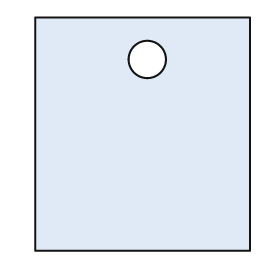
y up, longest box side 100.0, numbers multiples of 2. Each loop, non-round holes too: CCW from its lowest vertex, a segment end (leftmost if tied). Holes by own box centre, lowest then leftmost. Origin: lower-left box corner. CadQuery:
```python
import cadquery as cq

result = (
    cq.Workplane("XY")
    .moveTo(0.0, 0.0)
    .lineTo(92.0, 0.0)
    .lineTo(92.0, 100.0)
    .lineTo(0.0, 100.0)
    .close()
    .moveTo(48.0, 82.0)
    .circle(8.0)
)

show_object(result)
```